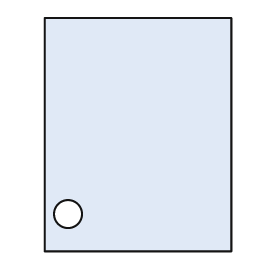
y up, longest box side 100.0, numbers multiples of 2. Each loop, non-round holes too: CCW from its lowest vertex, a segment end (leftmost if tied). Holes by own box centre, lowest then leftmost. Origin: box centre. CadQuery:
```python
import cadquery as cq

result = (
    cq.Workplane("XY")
    .moveTo(-40.0, -50.0)
    .lineTo(40.0, -50.0)
    .lineTo(40.0, 50.0)
    .lineTo(-40.0, 50.0)
    .close()
    .moveTo(-30.0, -34.0)
    .circle(6.0)
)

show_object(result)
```